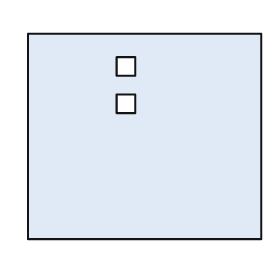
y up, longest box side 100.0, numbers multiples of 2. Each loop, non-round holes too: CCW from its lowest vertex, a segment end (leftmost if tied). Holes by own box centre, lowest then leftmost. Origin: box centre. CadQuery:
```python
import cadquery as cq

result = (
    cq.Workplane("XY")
    .moveTo(-50.0, -44.0)
    .lineTo(50.0, -44.0)
    .lineTo(50.0, 44.0)
    .lineTo(-50.0, 44.0)
    .close()
    .moveTo(-12.0, 10.0)
    .lineTo(-4.0, 10.0)
    .lineTo(-4.0, 18.0)
    .lineTo(-12.0, 18.0)
    .close()
    .moveTo(-12.0, 26.0)
    .lineTo(-4.0, 26.0)
    .lineTo(-4.0, 34.0)
    .lineTo(-12.0, 34.0)
    .close()
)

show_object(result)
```